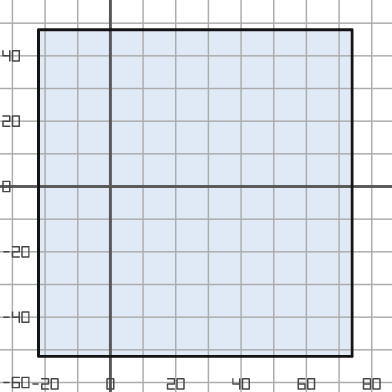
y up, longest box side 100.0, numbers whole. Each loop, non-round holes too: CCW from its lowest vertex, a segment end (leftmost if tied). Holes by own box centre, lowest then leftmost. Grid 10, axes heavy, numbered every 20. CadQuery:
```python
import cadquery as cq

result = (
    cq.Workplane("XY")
    .moveTo(-22.0, -52.0)
    .lineTo(74.0, -52.0)
    .lineTo(74.0, 48.0)
    .lineTo(-22.0, 48.0)
    .close()
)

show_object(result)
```